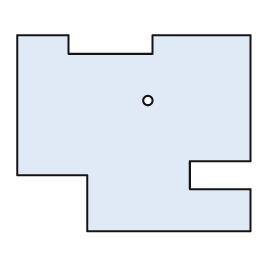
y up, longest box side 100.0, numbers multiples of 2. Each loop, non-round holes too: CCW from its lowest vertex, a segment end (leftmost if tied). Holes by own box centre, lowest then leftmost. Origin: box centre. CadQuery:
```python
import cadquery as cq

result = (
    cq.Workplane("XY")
    .moveTo(-20.0, -42.0)
    .lineTo(50.0, -42.0)
    .lineTo(50.0, -24.0)
    .lineTo(24.0, -24.0)
    .lineTo(24.0, -12.0)
    .lineTo(50.0, -12.0)
    .lineTo(50.0, 42.0)
    .lineTo(8.0, 42.0)
    .lineTo(8.0, 34.0)
    .lineTo(-28.0, 34.0)
    .lineTo(-28.0, 42.0)
    .lineTo(-50.0, 42.0)
    .lineTo(-50.0, -18.0)
    .lineTo(-20.0, -18.0)
    .close()
    .moveTo(6.0, 14.0)
    .circle(2.0)
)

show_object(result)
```